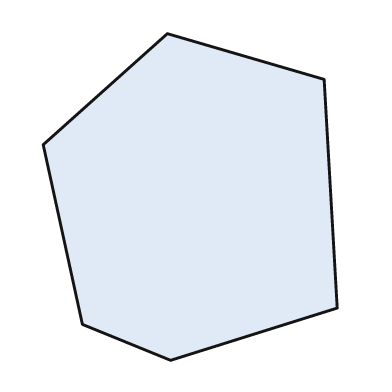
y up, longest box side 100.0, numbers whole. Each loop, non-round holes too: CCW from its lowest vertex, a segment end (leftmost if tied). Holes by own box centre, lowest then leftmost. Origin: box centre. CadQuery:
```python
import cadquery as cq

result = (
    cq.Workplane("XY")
    .moveTo(-6.0, -50.0)
    .lineTo(45.0, -34.0)
    .lineTo(41.0, 36.0)
    .lineTo(-7.0, 50.0)
    .lineTo(-45.0, 16.0)
    .lineTo(-33.0, -39.0)
    .close()
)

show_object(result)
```